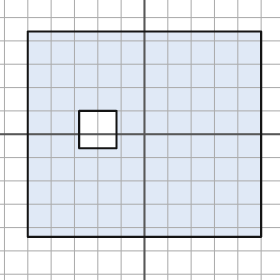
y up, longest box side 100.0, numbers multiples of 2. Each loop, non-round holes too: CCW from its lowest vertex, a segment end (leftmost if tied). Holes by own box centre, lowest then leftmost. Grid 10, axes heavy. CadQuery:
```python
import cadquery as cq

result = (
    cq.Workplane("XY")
    .moveTo(-50.0, -44.0)
    .lineTo(50.0, -44.0)
    .lineTo(50.0, 44.0)
    .lineTo(-50.0, 44.0)
    .close()
    .moveTo(-28.0, -6.0)
    .lineTo(-12.0, -6.0)
    .lineTo(-12.0, 10.0)
    .lineTo(-28.0, 10.0)
    .close()
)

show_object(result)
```